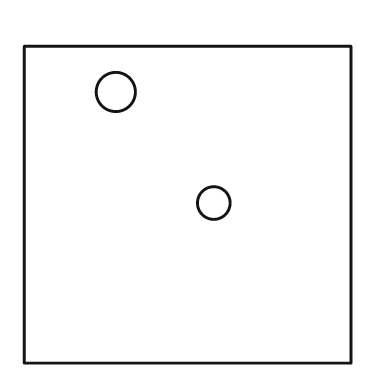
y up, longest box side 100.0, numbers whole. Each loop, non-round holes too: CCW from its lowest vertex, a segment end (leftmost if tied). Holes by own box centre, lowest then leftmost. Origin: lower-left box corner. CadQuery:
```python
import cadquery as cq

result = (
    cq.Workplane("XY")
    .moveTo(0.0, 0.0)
    .lineTo(100.0, 0.0)
    .lineTo(100.0, 97.0)
    .lineTo(0.0, 97.0)
    .close()
    .moveTo(58.0, 49.0)
    .circle(5.0)
    .moveTo(28.0, 83.0)
    .circle(6.0)
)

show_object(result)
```